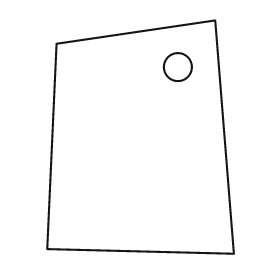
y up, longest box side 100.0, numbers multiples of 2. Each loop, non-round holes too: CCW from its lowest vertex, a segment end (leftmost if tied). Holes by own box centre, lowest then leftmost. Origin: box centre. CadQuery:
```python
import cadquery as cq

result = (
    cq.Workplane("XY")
    .moveTo(40.0, -50.0)
    .lineTo(32.0, 50.0)
    .lineTo(-36.0, 40.0)
    .lineTo(-40.0, -48.0)
    .close()
    .moveTo(16.0, 30.0)
    .circle(6.0)
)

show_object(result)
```